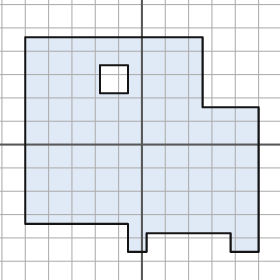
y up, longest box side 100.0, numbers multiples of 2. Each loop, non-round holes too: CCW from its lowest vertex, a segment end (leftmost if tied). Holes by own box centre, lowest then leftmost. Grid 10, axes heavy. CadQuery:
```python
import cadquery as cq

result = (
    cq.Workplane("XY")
    .moveTo(-6.0, -46.0)
    .lineTo(2.0, -46.0)
    .lineTo(2.0, -38.0)
    .lineTo(38.0, -38.0)
    .lineTo(38.0, -46.0)
    .lineTo(50.0, -46.0)
    .lineTo(50.0, 16.0)
    .lineTo(26.0, 16.0)
    .lineTo(26.0, 46.0)
    .lineTo(-50.0, 46.0)
    .lineTo(-50.0, -34.0)
    .lineTo(-6.0, -34.0)
    .close()
    .moveTo(-18.0, 22.0)
    .lineTo(-6.0, 22.0)
    .lineTo(-6.0, 34.0)
    .lineTo(-18.0, 34.0)
    .close()
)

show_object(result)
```